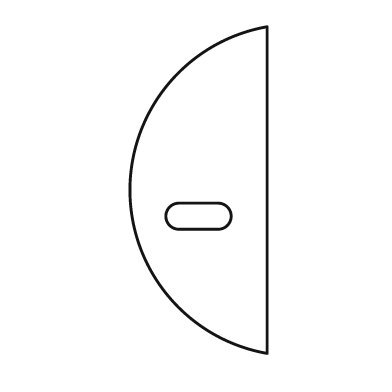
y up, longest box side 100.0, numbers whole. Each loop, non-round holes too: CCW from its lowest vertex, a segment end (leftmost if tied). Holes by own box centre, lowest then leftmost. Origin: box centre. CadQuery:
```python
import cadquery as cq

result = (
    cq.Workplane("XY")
    .moveTo(21.0, -50.0)
    .lineTo(21.0, 50.0)
    .threePointArc((-21.0, 0.0), (21.0, -50.0))
    .close()
    .moveTo(-6.0, -12.0)
    .lineTo(6.0, -12.0)
    .threePointArc((10.0, -8.0), (6.0, -4.0))
    .lineTo(-6.0, -4.0)
    .threePointArc((-10.0, -8.0), (-6.0, -12.0))
    .close()
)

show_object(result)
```